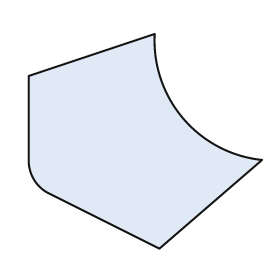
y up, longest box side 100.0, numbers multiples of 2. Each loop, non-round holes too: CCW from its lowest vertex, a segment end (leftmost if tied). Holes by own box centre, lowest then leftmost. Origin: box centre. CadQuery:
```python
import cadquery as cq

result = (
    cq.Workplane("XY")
    .moveTo(6.0, -46.0)
    .lineTo(50.0, -8.0)
    .threePointArc((16.0, 10.0), (4.0, 46.0))
    .lineTo(-50.0, 28.0)
    .lineTo(-50.0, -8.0)
    .threePointArc((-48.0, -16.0), (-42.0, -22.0))
    .close()
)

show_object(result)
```